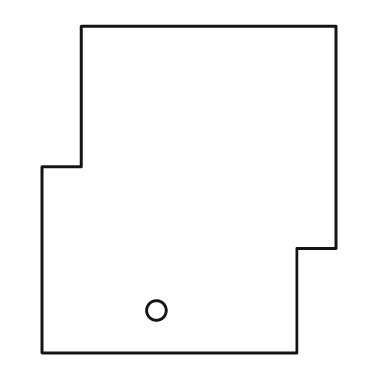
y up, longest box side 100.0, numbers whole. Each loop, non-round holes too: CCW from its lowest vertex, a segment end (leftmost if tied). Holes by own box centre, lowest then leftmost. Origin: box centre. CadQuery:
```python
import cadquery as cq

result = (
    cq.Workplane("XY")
    .moveTo(-45.0, -50.0)
    .lineTo(33.0, -50.0)
    .lineTo(33.0, -18.0)
    .lineTo(45.0, -18.0)
    .lineTo(45.0, 50.0)
    .lineTo(-33.0, 50.0)
    .lineTo(-33.0, 7.0)
    .lineTo(-45.0, 7.0)
    .close()
    .moveTo(-10.0, -37.0)
    .circle(3.0)
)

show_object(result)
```